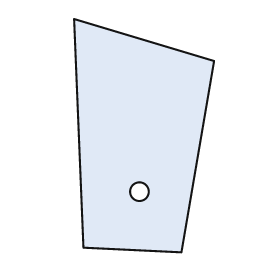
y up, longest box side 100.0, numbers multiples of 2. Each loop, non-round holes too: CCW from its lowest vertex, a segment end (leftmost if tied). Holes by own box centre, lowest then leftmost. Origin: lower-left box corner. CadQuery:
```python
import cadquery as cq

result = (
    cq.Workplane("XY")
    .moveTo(46.0, 0.0)
    .lineTo(60.0, 82.0)
    .lineTo(0.0, 100.0)
    .lineTo(4.0, 2.0)
    .close()
    .moveTo(28.0, 26.0)
    .circle(4.0)
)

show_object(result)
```